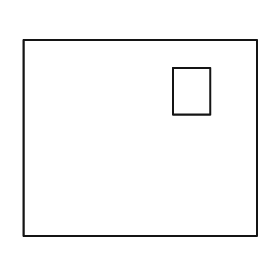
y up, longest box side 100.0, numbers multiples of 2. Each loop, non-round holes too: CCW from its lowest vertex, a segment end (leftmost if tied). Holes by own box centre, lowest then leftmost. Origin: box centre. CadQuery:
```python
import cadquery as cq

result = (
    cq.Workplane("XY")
    .moveTo(-50.0, -42.0)
    .lineTo(50.0, -42.0)
    .lineTo(50.0, 42.0)
    .lineTo(-50.0, 42.0)
    .close()
    .moveTo(14.0, 10.0)
    .lineTo(30.0, 10.0)
    .lineTo(30.0, 30.0)
    .lineTo(14.0, 30.0)
    .close()
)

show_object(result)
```